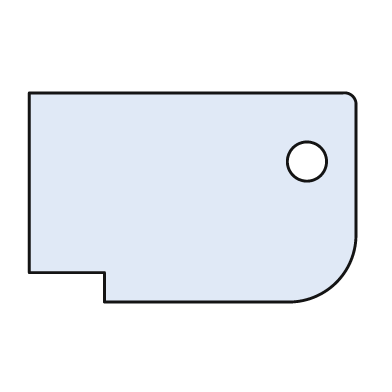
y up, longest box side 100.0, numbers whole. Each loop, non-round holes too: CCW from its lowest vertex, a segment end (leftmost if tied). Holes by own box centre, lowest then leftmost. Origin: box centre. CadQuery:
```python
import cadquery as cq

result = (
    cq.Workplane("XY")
    .moveTo(-27.0, -32.0)
    .lineTo(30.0, -32.0)
    .threePointArc((44.0, -26.0), (50.0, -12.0))
    .lineTo(50.0, 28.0)
    .threePointArc((49.0, 31.0), (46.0, 32.0))
    .lineTo(-50.0, 32.0)
    .lineTo(-50.0, -23.0)
    .lineTo(-27.0, -23.0)
    .close()
    .moveTo(35.0, 11.0)
    .circle(6.0)
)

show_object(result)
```